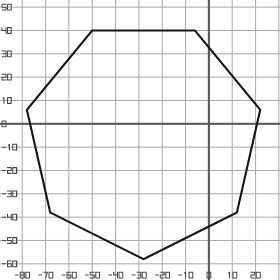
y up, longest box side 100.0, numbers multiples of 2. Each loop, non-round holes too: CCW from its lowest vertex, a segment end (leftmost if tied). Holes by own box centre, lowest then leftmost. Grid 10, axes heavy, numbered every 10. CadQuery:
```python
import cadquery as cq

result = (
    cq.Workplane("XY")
    .moveTo(-28.0, -58.0)
    .lineTo(12.0, -38.0)
    .lineTo(22.0, 6.0)
    .lineTo(-6.0, 40.0)
    .lineTo(-50.0, 40.0)
    .lineTo(-78.0, 6.0)
    .lineTo(-68.0, -38.0)
    .close()
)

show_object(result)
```